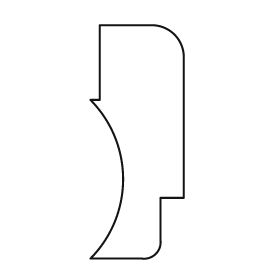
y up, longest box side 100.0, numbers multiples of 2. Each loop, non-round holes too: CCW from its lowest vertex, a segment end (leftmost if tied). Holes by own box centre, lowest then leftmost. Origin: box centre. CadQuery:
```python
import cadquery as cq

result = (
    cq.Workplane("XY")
    .moveTo(-20.0, -50.0)
    .lineTo(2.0, -50.0)
    .threePointArc((8.0, -48.0), (10.0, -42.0))
    .lineTo(10.0, -24.0)
    .lineTo(20.0, -24.0)
    .lineTo(20.0, 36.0)
    .threePointArc((16.0, 46.0), (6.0, 50.0))
    .lineTo(-16.0, 50.0)
    .lineTo(-16.0, 18.0)
    .lineTo(-20.0, 18.0)
    .threePointArc((-6.0, -16.0), (-20.0, -50.0))
    .close()
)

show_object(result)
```